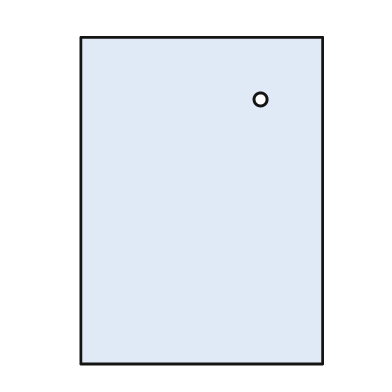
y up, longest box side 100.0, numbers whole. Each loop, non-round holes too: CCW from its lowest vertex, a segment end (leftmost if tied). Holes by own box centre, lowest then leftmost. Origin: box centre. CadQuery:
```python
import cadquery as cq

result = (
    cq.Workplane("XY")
    .moveTo(-37.0, -50.0)
    .lineTo(37.0, -50.0)
    .lineTo(37.0, 50.0)
    .lineTo(-37.0, 50.0)
    .close()
    .moveTo(18.0, 31.0)
    .circle(2.0)
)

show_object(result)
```